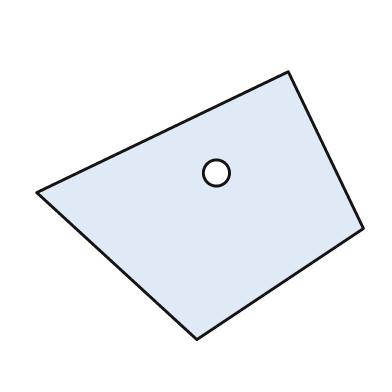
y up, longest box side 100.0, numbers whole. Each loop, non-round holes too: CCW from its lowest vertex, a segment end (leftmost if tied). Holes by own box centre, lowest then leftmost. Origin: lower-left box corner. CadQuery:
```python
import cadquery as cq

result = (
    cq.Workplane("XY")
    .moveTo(49.0, 0.0)
    .lineTo(100.0, 34.0)
    .lineTo(77.0, 82.0)
    .lineTo(0.0, 45.0)
    .close()
    .moveTo(55.0, 51.0)
    .circle(4.0)
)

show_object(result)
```